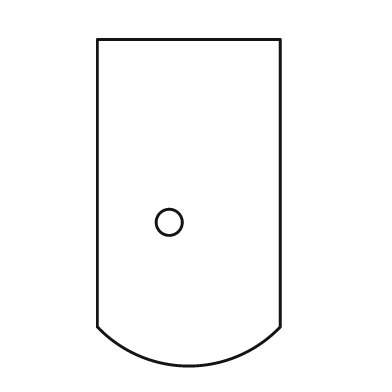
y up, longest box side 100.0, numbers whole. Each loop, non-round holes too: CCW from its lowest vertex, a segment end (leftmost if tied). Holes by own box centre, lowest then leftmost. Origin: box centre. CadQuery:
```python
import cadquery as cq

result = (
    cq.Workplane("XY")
    .moveTo(-28.0, -38.0)
    .threePointArc((0.0, -50.0), (28.0, -38.0))
    .lineTo(28.0, 50.0)
    .lineTo(-28.0, 50.0)
    .close()
    .moveTo(-6.0, -6.0)
    .circle(4.0)
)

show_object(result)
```